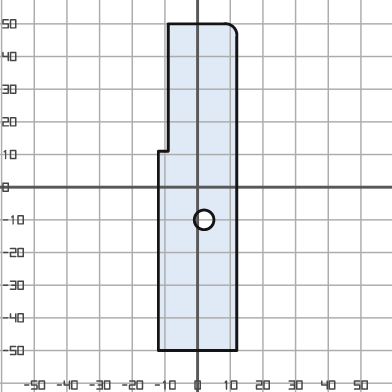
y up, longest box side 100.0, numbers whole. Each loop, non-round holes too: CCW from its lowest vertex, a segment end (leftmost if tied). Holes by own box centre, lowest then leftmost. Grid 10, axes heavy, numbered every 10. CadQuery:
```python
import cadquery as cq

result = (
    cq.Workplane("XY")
    .moveTo(-12.0, -50.0)
    .lineTo(12.0, -50.0)
    .lineTo(12.0, 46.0)
    .threePointArc((11.0, 49.0), (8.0, 50.0))
    .lineTo(-9.0, 50.0)
    .lineTo(-9.0, 11.0)
    .lineTo(-12.0, 11.0)
    .close()
    .moveTo(2.0, -10.0)
    .circle(3.0)
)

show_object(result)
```